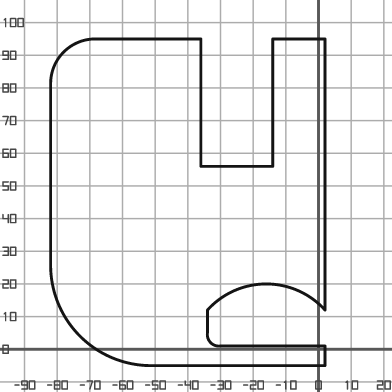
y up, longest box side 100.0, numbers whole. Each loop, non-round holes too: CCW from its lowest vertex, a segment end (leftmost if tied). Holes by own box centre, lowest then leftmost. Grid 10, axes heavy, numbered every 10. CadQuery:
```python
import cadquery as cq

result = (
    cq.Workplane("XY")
    .moveTo(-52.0, -5.0)
    .lineTo(2.0, -5.0)
    .lineTo(2.0, 1.0)
    .lineTo(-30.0, 1.0)
    .threePointArc((-33.0, 2.0), (-34.0, 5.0))
    .lineTo(-34.0, 12.0)
    .threePointArc((-16.0, 20.0), (2.0, 12.0))
    .lineTo(2.0, 95.0)
    .lineTo(-14.0, 95.0)
    .lineTo(-14.0, 56.0)
    .lineTo(-36.0, 56.0)
    .lineTo(-36.0, 95.0)
    .lineTo(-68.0, 95.0)
    .threePointArc((-78.0, 91.0), (-82.0, 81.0))
    .lineTo(-82.0, 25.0)
    .threePointArc((-73.0, 4.0), (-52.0, -5.0))
    .close()
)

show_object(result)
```